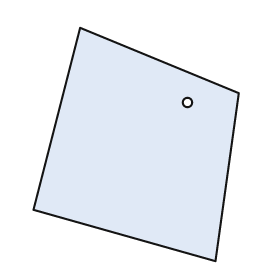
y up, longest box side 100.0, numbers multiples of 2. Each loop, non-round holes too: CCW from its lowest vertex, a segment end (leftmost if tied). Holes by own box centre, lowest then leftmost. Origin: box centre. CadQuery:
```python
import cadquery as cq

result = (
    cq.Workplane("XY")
    .moveTo(34.0, -50.0)
    .lineTo(44.0, 22.0)
    .lineTo(-24.0, 50.0)
    .lineTo(-44.0, -28.0)
    .close()
    .moveTo(22.0, 18.0)
    .circle(2.0)
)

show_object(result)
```